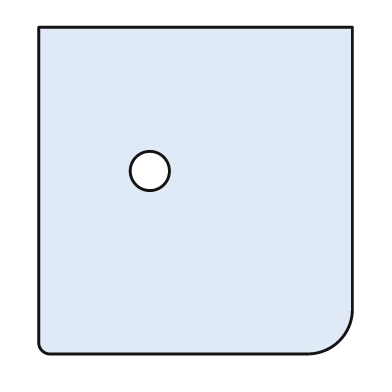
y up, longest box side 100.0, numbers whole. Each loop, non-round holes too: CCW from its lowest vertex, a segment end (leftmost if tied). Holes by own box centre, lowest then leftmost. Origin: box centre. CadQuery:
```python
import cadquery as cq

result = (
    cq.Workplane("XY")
    .moveTo(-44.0, -50.0)
    .lineTo(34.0, -50.0)
    .threePointArc((44.0, -46.0), (48.0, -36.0))
    .lineTo(48.0, 50.0)
    .lineTo(-48.0, 50.0)
    .lineTo(-48.0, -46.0)
    .threePointArc((-47.0, -49.0), (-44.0, -50.0))
    .close()
    .moveTo(-14.0, 6.0)
    .circle(6.0)
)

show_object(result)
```